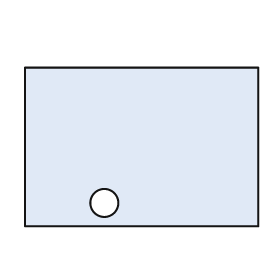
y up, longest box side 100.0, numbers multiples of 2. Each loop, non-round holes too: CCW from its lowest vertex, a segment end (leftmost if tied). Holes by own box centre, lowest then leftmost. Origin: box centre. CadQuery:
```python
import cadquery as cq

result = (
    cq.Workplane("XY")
    .moveTo(-50.0, -34.0)
    .lineTo(50.0, -34.0)
    .lineTo(50.0, 34.0)
    .lineTo(-50.0, 34.0)
    .close()
    .moveTo(-16.0, -24.0)
    .circle(6.0)
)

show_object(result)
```